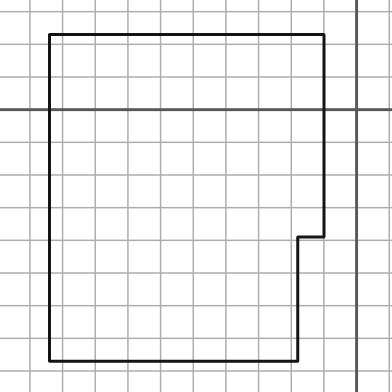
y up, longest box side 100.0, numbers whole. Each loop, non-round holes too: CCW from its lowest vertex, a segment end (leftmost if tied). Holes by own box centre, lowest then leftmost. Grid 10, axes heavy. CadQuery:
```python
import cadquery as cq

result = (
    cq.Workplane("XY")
    .moveTo(-94.0, -77.0)
    .lineTo(-18.0, -77.0)
    .lineTo(-18.0, -39.0)
    .lineTo(-10.0, -39.0)
    .lineTo(-10.0, 23.0)
    .lineTo(-94.0, 23.0)
    .close()
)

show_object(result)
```